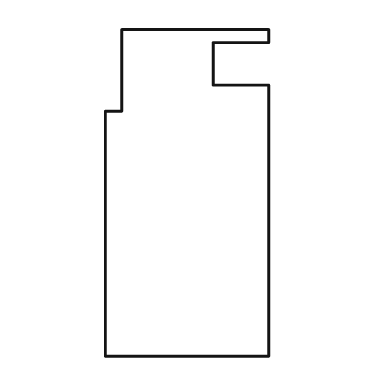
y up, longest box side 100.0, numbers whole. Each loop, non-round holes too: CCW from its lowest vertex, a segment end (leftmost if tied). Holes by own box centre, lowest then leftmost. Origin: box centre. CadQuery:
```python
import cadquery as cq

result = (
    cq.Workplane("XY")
    .moveTo(-25.0, -50.0)
    .lineTo(25.0, -50.0)
    .lineTo(25.0, 33.0)
    .lineTo(8.0, 33.0)
    .lineTo(8.0, 46.0)
    .lineTo(25.0, 46.0)
    .lineTo(25.0, 50.0)
    .lineTo(-20.0, 50.0)
    .lineTo(-20.0, 25.0)
    .lineTo(-25.0, 25.0)
    .close()
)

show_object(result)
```